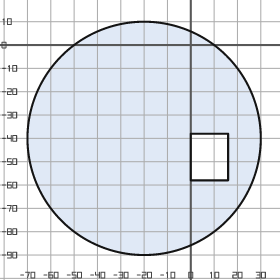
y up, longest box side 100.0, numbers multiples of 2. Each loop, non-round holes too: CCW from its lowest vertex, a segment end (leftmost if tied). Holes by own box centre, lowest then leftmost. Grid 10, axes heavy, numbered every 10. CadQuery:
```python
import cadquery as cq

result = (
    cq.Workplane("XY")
    .moveTo(-20.0, -40.0)
    .circle(50.0)
    .moveTo(0.0, -58.0)
    .lineTo(16.0, -58.0)
    .lineTo(16.0, -38.0)
    .lineTo(0.0, -38.0)
    .close()
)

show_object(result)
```